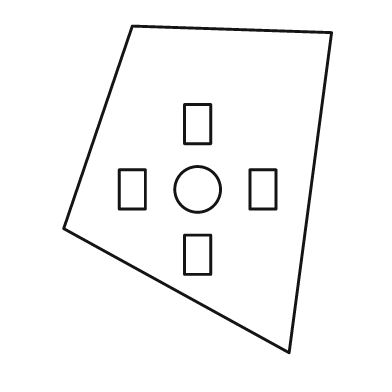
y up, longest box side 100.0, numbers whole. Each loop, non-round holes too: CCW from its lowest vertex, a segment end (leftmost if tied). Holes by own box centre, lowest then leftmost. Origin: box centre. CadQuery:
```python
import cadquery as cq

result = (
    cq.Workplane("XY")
    .moveTo(28.0, -50.0)
    .lineTo(41.0, 48.0)
    .lineTo(-20.0, 50.0)
    .lineTo(-41.0, -12.0)
    .close()
    .moveTo(-4.0, -26.0)
    .lineTo(4.0, -26.0)
    .lineTo(4.0, -14.0)
    .lineTo(-4.0, -14.0)
    .close()
    .moveTo(-24.0, -6.0)
    .lineTo(-16.0, -6.0)
    .lineTo(-16.0, 6.0)
    .lineTo(-24.0, 6.0)
    .close()
    .moveTo(0.0, 0.0)
    .circle(7.0)
    .moveTo(16.0, -6.0)
    .lineTo(24.0, -6.0)
    .lineTo(24.0, 6.0)
    .lineTo(16.0, 6.0)
    .close()
    .moveTo(-4.0, 14.0)
    .lineTo(4.0, 14.0)
    .lineTo(4.0, 26.0)
    .lineTo(-4.0, 26.0)
    .close()
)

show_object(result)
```